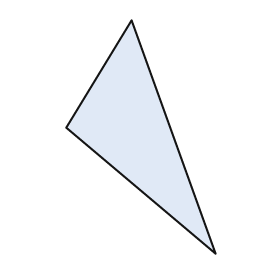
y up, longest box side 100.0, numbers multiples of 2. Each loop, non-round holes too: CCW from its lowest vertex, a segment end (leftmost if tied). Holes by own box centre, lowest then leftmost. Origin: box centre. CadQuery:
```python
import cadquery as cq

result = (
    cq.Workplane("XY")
    .moveTo(32.0, -50.0)
    .lineTo(-4.0, 50.0)
    .lineTo(-32.0, 4.0)
    .close()
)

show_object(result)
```